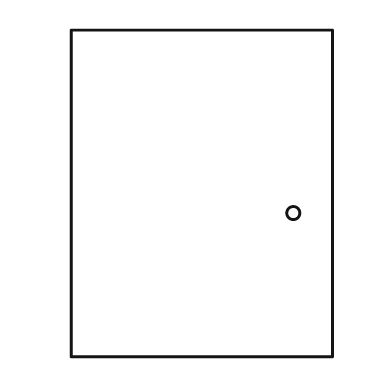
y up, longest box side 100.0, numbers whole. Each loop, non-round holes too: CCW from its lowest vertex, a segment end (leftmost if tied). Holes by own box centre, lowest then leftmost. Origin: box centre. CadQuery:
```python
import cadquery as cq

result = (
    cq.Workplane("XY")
    .moveTo(-40.0, -50.0)
    .lineTo(40.0, -50.0)
    .lineTo(40.0, 50.0)
    .lineTo(-40.0, 50.0)
    .close()
    .moveTo(28.0, -6.0)
    .circle(2.0)
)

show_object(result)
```